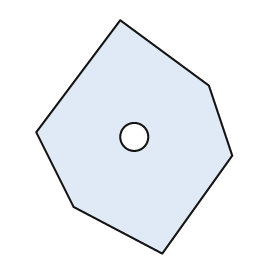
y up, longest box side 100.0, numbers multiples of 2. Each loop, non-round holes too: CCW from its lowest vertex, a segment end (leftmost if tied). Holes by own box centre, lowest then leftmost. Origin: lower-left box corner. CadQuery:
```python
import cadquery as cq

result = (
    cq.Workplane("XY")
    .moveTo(54.0, 0.0)
    .lineTo(84.0, 42.0)
    .lineTo(74.0, 72.0)
    .lineTo(36.0, 100.0)
    .lineTo(0.0, 52.0)
    .lineTo(16.0, 20.0)
    .close()
    .moveTo(42.0, 50.0)
    .circle(6.0)
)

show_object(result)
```